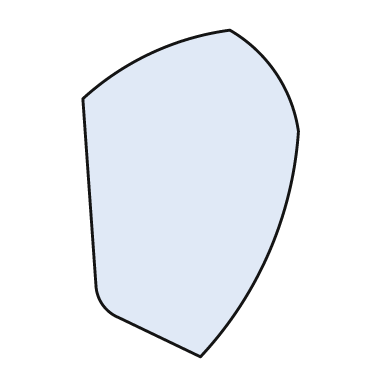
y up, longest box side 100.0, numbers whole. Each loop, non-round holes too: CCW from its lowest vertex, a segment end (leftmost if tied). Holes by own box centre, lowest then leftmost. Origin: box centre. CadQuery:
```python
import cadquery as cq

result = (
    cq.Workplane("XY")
    .moveTo(3.0, -50.0)
    .threePointArc((24.0, -18.0), (33.0, 19.0))
    .threePointArc((26.0, 37.0), (12.0, 50.0))
    .threePointArc((-12.0, 43.0), (-33.0, 29.0))
    .lineTo(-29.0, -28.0)
    .threePointArc((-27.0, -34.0), (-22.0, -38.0))
    .close()
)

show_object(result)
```